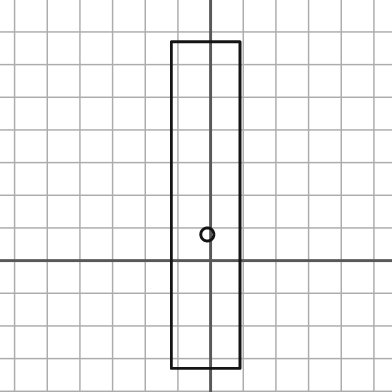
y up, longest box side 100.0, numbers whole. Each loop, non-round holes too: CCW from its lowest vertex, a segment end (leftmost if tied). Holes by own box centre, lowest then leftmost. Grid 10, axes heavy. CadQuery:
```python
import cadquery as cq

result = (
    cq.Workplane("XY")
    .moveTo(-12.0, -33.0)
    .lineTo(9.0, -33.0)
    .lineTo(9.0, 67.0)
    .lineTo(-12.0, 67.0)
    .close()
    .moveTo(-1.0, 8.0)
    .circle(2.0)
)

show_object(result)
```